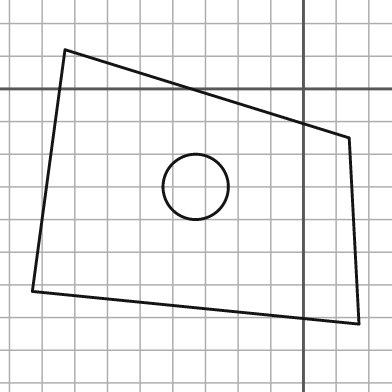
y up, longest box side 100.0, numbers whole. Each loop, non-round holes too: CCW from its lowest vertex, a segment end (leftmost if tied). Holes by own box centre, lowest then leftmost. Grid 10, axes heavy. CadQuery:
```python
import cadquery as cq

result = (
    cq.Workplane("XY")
    .moveTo(17.0, -72.0)
    .lineTo(14.0, -15.0)
    .lineTo(-73.0, 12.0)
    .lineTo(-83.0, -62.0)
    .close()
    .moveTo(-33.0, -30.0)
    .circle(10.0)
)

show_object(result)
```